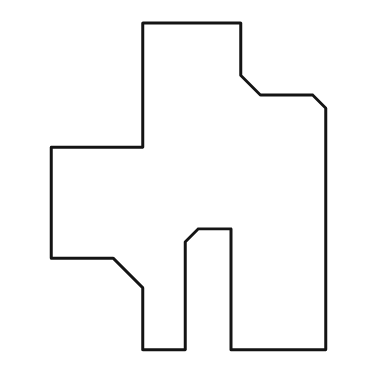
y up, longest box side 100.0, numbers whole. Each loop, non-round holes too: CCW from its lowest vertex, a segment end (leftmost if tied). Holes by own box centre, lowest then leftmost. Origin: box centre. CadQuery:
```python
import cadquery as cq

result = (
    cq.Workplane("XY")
    .moveTo(-14.0, -50.0)
    .lineTo(-1.0, -50.0)
    .lineTo(-1.0, -17.0)
    .lineTo(3.0, -13.0)
    .lineTo(13.0, -13.0)
    .lineTo(13.0, -50.0)
    .lineTo(42.0, -50.0)
    .lineTo(42.0, 24.0)
    .lineTo(38.0, 28.0)
    .lineTo(22.0, 28.0)
    .lineTo(16.0, 34.0)
    .lineTo(16.0, 50.0)
    .lineTo(-14.0, 50.0)
    .lineTo(-14.0, 12.0)
    .lineTo(-42.0, 12.0)
    .lineTo(-42.0, -22.0)
    .lineTo(-23.0, -22.0)
    .lineTo(-14.0, -31.0)
    .close()
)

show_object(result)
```